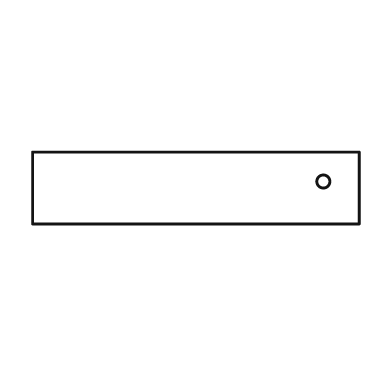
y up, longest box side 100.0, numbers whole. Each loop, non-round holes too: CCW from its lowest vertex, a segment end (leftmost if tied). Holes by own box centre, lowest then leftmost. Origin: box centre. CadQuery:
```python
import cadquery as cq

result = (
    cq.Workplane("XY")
    .moveTo(-50.0, -11.0)
    .lineTo(50.0, -11.0)
    .lineTo(50.0, 11.0)
    .lineTo(-50.0, 11.0)
    .close()
    .moveTo(39.0, 2.0)
    .circle(2.0)
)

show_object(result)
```